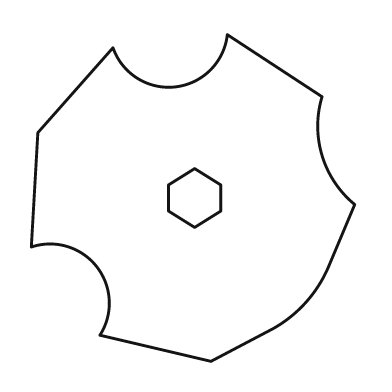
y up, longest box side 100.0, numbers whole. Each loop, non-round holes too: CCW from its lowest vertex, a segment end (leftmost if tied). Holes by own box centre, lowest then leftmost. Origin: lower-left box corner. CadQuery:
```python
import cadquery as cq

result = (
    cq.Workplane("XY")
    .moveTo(55.0, 0.0)
    .lineTo(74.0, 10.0)
    .threePointArc((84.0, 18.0), (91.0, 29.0))
    .lineTo(99.0, 48.0)
    .threePointArc((89.0, 63.0), (89.0, 81.0))
    .lineTo(60.0, 100.0)
    .threePointArc((44.0, 84.0), (25.0, 96.0))
    .lineTo(2.0, 70.0)
    .lineTo(0.0, 35.0)
    .threePointArc((20.0, 29.0), (21.0, 8.0))
    .close()
    .moveTo(50.0, 41.0)
    .lineTo(58.0, 46.0)
    .lineTo(58.0, 54.0)
    .lineTo(50.0, 59.0)
    .lineTo(42.0, 54.0)
    .lineTo(42.0, 46.0)
    .close()
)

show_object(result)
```